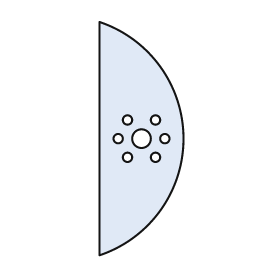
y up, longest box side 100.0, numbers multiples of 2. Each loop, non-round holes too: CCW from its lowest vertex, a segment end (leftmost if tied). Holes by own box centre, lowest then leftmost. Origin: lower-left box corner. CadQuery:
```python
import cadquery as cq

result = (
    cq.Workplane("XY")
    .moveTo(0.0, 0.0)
    .threePointArc((36.0, 50.0), (0.0, 100.0))
    .close()
    .moveTo(12.0, 42.0)
    .circle(2.0)
    .moveTo(24.0, 42.0)
    .circle(2.0)
    .moveTo(8.0, 50.0)
    .circle(2.0)
    .moveTo(18.0, 50.0)
    .circle(4.0)
    .moveTo(28.0, 50.0)
    .circle(2.0)
    .moveTo(12.0, 58.0)
    .circle(2.0)
    .moveTo(24.0, 58.0)
    .circle(2.0)
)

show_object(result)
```